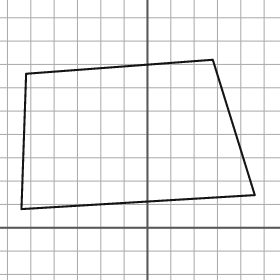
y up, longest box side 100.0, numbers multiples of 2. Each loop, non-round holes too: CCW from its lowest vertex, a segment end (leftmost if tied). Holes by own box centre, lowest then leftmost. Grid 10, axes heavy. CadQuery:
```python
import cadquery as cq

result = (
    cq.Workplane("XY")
    .moveTo(-54.0, 8.0)
    .lineTo(46.0, 14.0)
    .lineTo(28.0, 72.0)
    .lineTo(-52.0, 66.0)
    .close()
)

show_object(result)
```